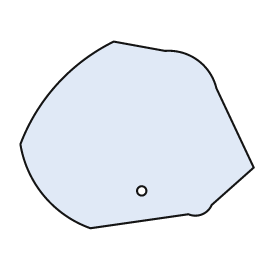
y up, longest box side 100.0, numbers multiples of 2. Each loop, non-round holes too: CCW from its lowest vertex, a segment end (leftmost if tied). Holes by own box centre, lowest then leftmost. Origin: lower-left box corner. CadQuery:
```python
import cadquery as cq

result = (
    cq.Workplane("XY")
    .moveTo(30.0, 0.0)
    .lineTo(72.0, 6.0)
    .threePointArc((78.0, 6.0), (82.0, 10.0))
    .lineTo(100.0, 26.0)
    .lineTo(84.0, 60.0)
    .threePointArc((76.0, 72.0), (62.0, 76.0))
    .lineTo(40.0, 80.0)
    .threePointArc((16.0, 62.0), (0.0, 36.0))
    .threePointArc((10.0, 14.0), (30.0, 0.0))
    .close()
    .moveTo(52.0, 16.0)
    .circle(2.0)
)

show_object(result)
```